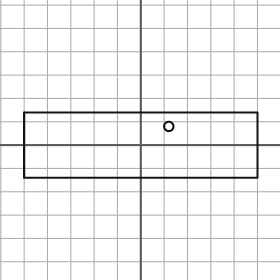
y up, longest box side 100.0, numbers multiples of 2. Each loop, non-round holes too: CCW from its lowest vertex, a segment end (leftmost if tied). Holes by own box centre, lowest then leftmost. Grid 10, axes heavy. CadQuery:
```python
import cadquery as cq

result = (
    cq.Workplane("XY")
    .moveTo(-50.0, -14.0)
    .lineTo(50.0, -14.0)
    .lineTo(50.0, 14.0)
    .lineTo(-50.0, 14.0)
    .close()
    .moveTo(12.0, 8.0)
    .circle(2.0)
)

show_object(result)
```